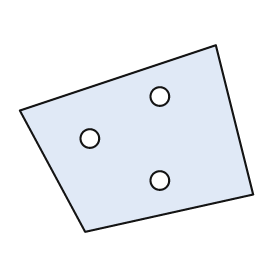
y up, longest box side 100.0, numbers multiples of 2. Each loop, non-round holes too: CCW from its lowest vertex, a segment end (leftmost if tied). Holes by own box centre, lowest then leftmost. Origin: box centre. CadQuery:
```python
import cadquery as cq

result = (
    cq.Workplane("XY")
    .moveTo(-22.0, -40.0)
    .lineTo(50.0, -24.0)
    .lineTo(34.0, 40.0)
    .lineTo(-50.0, 12.0)
    .close()
    .moveTo(10.0, -18.0)
    .circle(4.0)
    .moveTo(-20.0, 0.0)
    .circle(4.0)
    .moveTo(10.0, 18.0)
    .circle(4.0)
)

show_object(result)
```